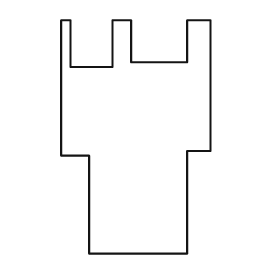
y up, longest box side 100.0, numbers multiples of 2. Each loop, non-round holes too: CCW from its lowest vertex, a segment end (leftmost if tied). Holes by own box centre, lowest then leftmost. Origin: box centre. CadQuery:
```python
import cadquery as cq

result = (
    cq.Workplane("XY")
    .moveTo(-20.0, -50.0)
    .lineTo(22.0, -50.0)
    .lineTo(22.0, -6.0)
    .lineTo(32.0, -6.0)
    .lineTo(32.0, 50.0)
    .lineTo(22.0, 50.0)
    .lineTo(22.0, 32.0)
    .lineTo(-2.0, 32.0)
    .lineTo(-2.0, 50.0)
    .lineTo(-10.0, 50.0)
    .lineTo(-10.0, 30.0)
    .lineTo(-28.0, 30.0)
    .lineTo(-28.0, 50.0)
    .lineTo(-32.0, 50.0)
    .lineTo(-32.0, -8.0)
    .lineTo(-20.0, -8.0)
    .close()
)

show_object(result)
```